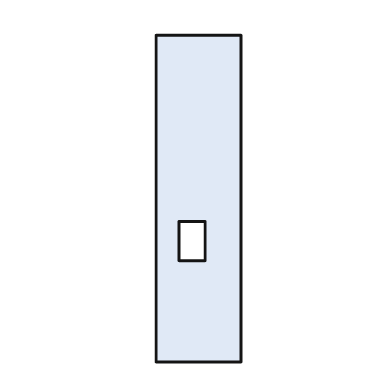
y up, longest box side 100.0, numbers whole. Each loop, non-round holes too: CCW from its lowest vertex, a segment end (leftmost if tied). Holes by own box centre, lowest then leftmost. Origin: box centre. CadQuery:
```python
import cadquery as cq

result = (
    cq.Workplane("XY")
    .moveTo(-13.0, -50.0)
    .lineTo(13.0, -50.0)
    .lineTo(13.0, 50.0)
    .lineTo(-13.0, 50.0)
    .close()
    .moveTo(-6.0, -19.0)
    .lineTo(2.0, -19.0)
    .lineTo(2.0, -7.0)
    .lineTo(-6.0, -7.0)
    .close()
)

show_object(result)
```